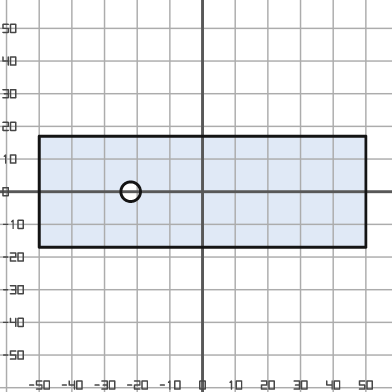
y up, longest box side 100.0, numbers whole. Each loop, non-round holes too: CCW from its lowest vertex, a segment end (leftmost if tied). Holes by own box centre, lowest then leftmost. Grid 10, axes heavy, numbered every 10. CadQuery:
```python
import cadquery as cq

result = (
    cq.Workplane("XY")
    .moveTo(-50.0, -17.0)
    .lineTo(50.0, -17.0)
    .lineTo(50.0, 17.0)
    .lineTo(-50.0, 17.0)
    .close()
    .moveTo(-22.0, 0.0)
    .circle(3.0)
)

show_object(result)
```